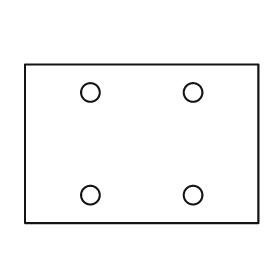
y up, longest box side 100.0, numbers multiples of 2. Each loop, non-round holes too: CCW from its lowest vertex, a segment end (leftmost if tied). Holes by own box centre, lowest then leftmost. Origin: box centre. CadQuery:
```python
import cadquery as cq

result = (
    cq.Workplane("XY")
    .moveTo(-50.0, -34.0)
    .lineTo(50.0, -34.0)
    .lineTo(50.0, 34.0)
    .lineTo(-50.0, 34.0)
    .close()
    .moveTo(-22.0, -22.0)
    .circle(4.0)
    .moveTo(22.0, -22.0)
    .circle(4.0)
    .moveTo(-22.0, 22.0)
    .circle(4.0)
    .moveTo(22.0, 22.0)
    .circle(4.0)
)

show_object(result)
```